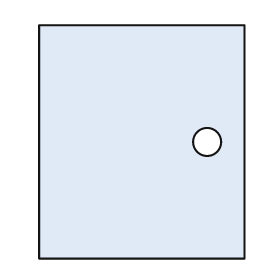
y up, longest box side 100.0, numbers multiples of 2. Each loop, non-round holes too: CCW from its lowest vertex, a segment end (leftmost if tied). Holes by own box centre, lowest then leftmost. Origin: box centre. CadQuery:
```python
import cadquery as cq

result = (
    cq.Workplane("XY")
    .moveTo(-44.0, -50.0)
    .lineTo(44.0, -50.0)
    .lineTo(44.0, 50.0)
    .lineTo(-44.0, 50.0)
    .close()
    .moveTo(28.0, 0.0)
    .circle(6.0)
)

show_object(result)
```